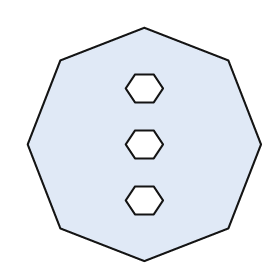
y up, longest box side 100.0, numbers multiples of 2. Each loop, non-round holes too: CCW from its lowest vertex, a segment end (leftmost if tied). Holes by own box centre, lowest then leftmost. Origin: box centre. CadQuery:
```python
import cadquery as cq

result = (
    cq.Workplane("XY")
    .moveTo(0.0, -50.0)
    .lineTo(36.0, -36.0)
    .lineTo(50.0, 0.0)
    .lineTo(36.0, 36.0)
    .lineTo(0.0, 50.0)
    .lineTo(-36.0, 36.0)
    .lineTo(-50.0, 0.0)
    .lineTo(-36.0, -36.0)
    .close()
    .moveTo(-4.0, -30.0)
    .lineTo(4.0, -30.0)
    .lineTo(8.0, -24.0)
    .lineTo(4.0, -18.0)
    .lineTo(-4.0, -18.0)
    .lineTo(-8.0, -24.0)
    .close()
    .moveTo(-4.0, -6.0)
    .lineTo(4.0, -6.0)
    .lineTo(8.0, 0.0)
    .lineTo(4.0, 6.0)
    .lineTo(-4.0, 6.0)
    .lineTo(-8.0, 0.0)
    .close()
    .moveTo(-4.0, 18.0)
    .lineTo(4.0, 18.0)
    .lineTo(8.0, 24.0)
    .lineTo(4.0, 30.0)
    .lineTo(-4.0, 30.0)
    .lineTo(-8.0, 24.0)
    .close()
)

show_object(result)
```